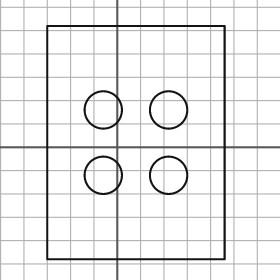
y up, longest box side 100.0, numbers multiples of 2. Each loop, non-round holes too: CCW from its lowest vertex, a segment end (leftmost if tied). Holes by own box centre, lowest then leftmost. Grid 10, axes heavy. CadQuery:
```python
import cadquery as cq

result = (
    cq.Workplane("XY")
    .moveTo(-30.0, -48.0)
    .lineTo(46.0, -48.0)
    .lineTo(46.0, 52.0)
    .lineTo(-30.0, 52.0)
    .close()
    .moveTo(-6.0, -12.0)
    .circle(8.0)
    .moveTo(22.0, -12.0)
    .circle(8.0)
    .moveTo(-6.0, 16.0)
    .circle(8.0)
    .moveTo(22.0, 16.0)
    .circle(8.0)
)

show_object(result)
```